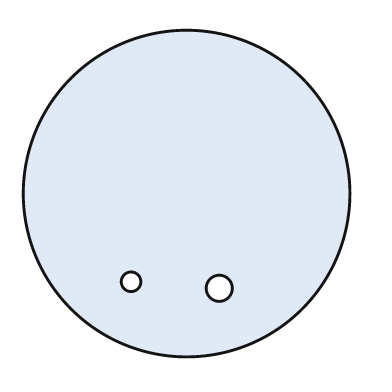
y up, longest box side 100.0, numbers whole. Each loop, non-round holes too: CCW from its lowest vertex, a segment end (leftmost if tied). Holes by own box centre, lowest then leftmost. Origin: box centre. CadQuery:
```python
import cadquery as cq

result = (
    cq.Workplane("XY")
    .moveTo(0.0, 0.0)
    .circle(50.0)
    .moveTo(10.0, -29.0)
    .circle(4.0)
    .moveTo(-17.0, -27.0)
    .circle(3.0)
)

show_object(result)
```